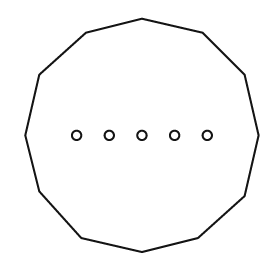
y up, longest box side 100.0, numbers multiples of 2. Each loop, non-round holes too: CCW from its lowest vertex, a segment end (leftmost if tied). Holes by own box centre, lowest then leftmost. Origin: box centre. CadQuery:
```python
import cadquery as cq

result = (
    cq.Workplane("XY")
    .moveTo(0.0, -50.0)
    .lineTo(24.0, -44.0)
    .lineTo(44.0, -26.0)
    .lineTo(50.0, 0.0)
    .lineTo(44.0, 26.0)
    .lineTo(26.0, 44.0)
    .lineTo(0.0, 50.0)
    .lineTo(-24.0, 44.0)
    .lineTo(-44.0, 26.0)
    .lineTo(-50.0, 0.0)
    .lineTo(-44.0, -24.0)
    .lineTo(-26.0, -44.0)
    .close()
    .moveTo(-28.0, 0.0)
    .circle(2.0)
    .moveTo(-14.0, 0.0)
    .circle(2.0)
    .moveTo(0.0, 0.0)
    .circle(2.0)
    .moveTo(14.0, 0.0)
    .circle(2.0)
    .moveTo(28.0, 0.0)
    .circle(2.0)
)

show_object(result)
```